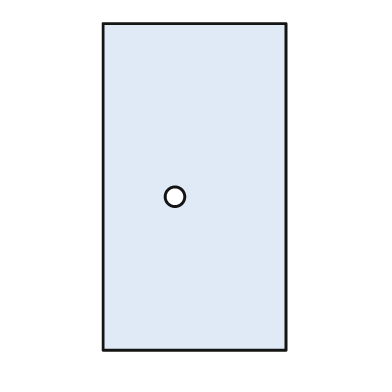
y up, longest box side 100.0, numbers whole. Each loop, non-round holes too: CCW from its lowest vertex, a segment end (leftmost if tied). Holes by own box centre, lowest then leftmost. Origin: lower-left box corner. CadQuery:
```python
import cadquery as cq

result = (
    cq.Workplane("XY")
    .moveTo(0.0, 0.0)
    .lineTo(56.0, 0.0)
    .lineTo(56.0, 100.0)
    .lineTo(0.0, 100.0)
    .close()
    .moveTo(22.0, 47.0)
    .circle(3.0)
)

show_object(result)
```